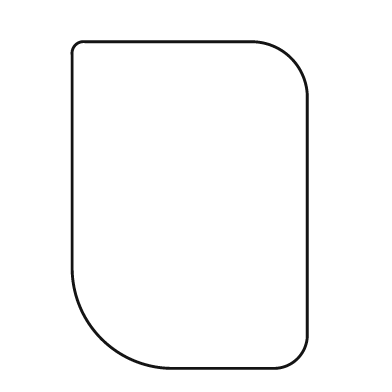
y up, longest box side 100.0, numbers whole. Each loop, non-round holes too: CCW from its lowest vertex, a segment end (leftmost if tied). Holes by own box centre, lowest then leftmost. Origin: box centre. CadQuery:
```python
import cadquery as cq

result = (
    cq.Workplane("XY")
    .moveTo(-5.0, -50.0)
    .lineTo(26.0, -50.0)
    .threePointArc((33.0, -47.0), (36.0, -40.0))
    .lineTo(36.0, 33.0)
    .threePointArc((31.0, 45.0), (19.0, 50.0))
    .lineTo(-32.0, 50.0)
    .threePointArc((-35.0, 49.0), (-36.0, 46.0))
    .lineTo(-36.0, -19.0)
    .threePointArc((-27.0, -41.0), (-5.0, -50.0))
    .close()
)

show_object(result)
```